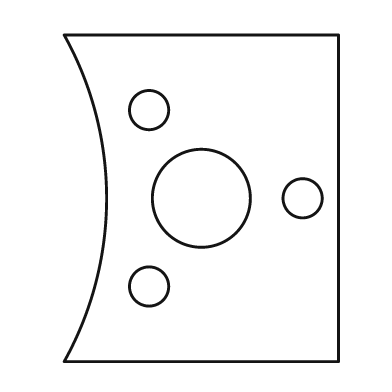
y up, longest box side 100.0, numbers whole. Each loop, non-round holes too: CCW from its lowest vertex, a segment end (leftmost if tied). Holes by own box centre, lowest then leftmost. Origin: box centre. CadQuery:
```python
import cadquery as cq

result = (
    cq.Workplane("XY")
    .moveTo(-42.0, -50.0)
    .lineTo(42.0, -50.0)
    .lineTo(42.0, 50.0)
    .lineTo(-42.0, 50.0)
    .threePointArc((-29.0, 0.0), (-42.0, -50.0))
    .close()
    .moveTo(-16.0, -27.0)
    .circle(6.0)
    .moveTo(0.0, 0.0)
    .circle(15.0)
    .moveTo(31.0, 0.0)
    .circle(6.0)
    .moveTo(-16.0, 27.0)
    .circle(6.0)
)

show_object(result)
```